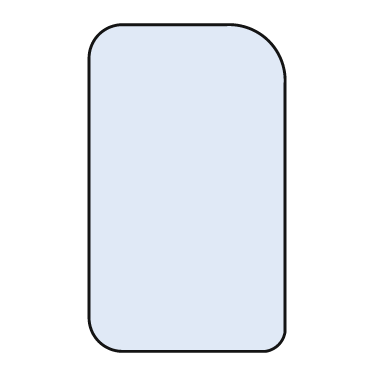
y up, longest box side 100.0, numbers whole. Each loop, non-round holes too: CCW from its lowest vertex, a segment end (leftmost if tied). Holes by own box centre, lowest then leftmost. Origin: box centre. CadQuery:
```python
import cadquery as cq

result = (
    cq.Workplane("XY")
    .moveTo(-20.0, -50.0)
    .lineTo(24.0, -50.0)
    .threePointArc((28.0, -48.0), (30.0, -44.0))
    .lineTo(30.0, 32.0)
    .threePointArc((25.0, 45.0), (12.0, 50.0))
    .lineTo(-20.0, 50.0)
    .threePointArc((-27.0, 47.0), (-30.0, 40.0))
    .lineTo(-30.0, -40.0)
    .threePointArc((-27.0, -47.0), (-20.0, -50.0))
    .close()
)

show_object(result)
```